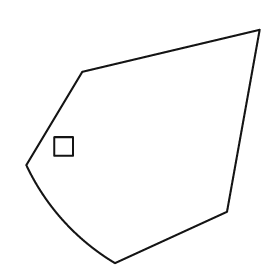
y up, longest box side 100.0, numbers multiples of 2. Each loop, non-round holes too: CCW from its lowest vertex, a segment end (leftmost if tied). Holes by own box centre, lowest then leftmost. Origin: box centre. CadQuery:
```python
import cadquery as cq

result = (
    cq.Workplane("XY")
    .moveTo(-12.0, -50.0)
    .lineTo(36.0, -28.0)
    .lineTo(50.0, 50.0)
    .lineTo(-26.0, 32.0)
    .lineTo(-50.0, -8.0)
    .threePointArc((-34.0, -32.0), (-12.0, -50.0))
    .close()
    .moveTo(-38.0, -4.0)
    .lineTo(-30.0, -4.0)
    .lineTo(-30.0, 4.0)
    .lineTo(-38.0, 4.0)
    .close()
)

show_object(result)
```